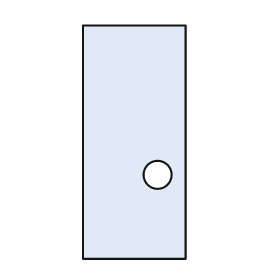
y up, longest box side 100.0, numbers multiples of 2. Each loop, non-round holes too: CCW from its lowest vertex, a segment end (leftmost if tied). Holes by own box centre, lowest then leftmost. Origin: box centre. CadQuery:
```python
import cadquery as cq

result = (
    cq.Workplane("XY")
    .moveTo(-22.0, -50.0)
    .lineTo(22.0, -50.0)
    .lineTo(22.0, 50.0)
    .lineTo(-22.0, 50.0)
    .close()
    .moveTo(10.0, -14.0)
    .circle(6.0)
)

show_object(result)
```